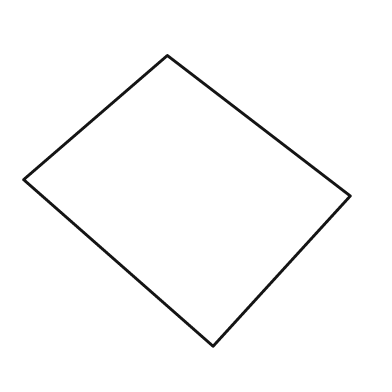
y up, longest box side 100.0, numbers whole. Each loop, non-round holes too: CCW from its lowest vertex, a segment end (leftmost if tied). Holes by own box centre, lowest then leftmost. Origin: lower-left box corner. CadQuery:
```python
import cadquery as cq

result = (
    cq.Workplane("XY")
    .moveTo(58.0, 0.0)
    .lineTo(100.0, 46.0)
    .lineTo(44.0, 89.0)
    .lineTo(0.0, 51.0)
    .close()
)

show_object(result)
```